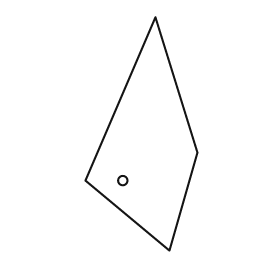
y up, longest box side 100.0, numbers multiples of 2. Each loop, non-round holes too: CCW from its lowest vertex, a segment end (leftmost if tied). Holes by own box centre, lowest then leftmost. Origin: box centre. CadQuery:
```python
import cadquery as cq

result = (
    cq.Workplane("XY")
    .moveTo(12.0, -50.0)
    .lineTo(24.0, -8.0)
    .lineTo(6.0, 50.0)
    .lineTo(-24.0, -20.0)
    .close()
    .moveTo(-8.0, -20.0)
    .circle(2.0)
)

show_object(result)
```